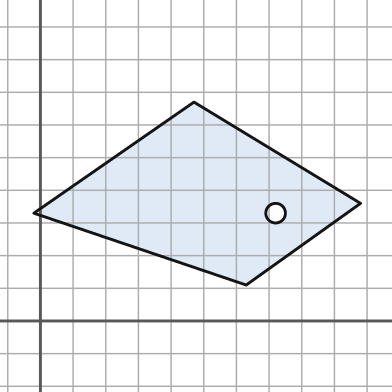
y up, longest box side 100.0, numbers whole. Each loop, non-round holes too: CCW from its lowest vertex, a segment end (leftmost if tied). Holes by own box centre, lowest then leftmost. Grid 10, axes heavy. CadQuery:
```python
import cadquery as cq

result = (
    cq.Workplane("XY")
    .moveTo(63.0, 11.0)
    .lineTo(98.0, 36.0)
    .lineTo(47.0, 67.0)
    .lineTo(-2.0, 33.0)
    .close()
    .moveTo(72.0, 33.0)
    .circle(3.0)
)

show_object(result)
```